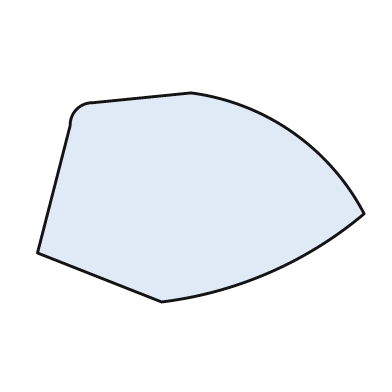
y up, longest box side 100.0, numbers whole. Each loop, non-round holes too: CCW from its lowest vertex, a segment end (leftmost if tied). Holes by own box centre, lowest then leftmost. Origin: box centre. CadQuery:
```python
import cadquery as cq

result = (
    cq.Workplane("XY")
    .moveTo(-12.0, -32.0)
    .threePointArc((21.0, -23.0), (50.0, -5.0))
    .threePointArc((28.0, 20.0), (-3.0, 32.0))
    .lineTo(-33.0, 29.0)
    .threePointArc((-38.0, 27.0), (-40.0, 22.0))
    .lineTo(-50.0, -17.0)
    .close()
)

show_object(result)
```